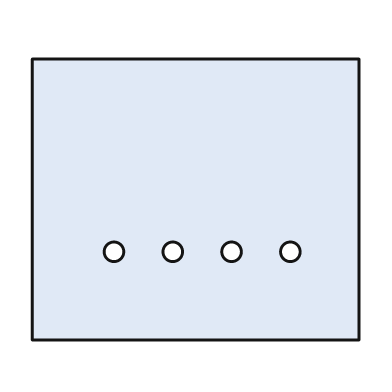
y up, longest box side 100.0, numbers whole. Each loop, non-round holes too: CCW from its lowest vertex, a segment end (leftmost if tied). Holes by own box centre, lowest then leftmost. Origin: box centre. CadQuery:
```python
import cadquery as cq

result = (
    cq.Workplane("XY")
    .moveTo(-50.0, -43.0)
    .lineTo(50.0, -43.0)
    .lineTo(50.0, 43.0)
    .lineTo(-50.0, 43.0)
    .close()
    .moveTo(-25.0, -16.0)
    .circle(3.0)
    .moveTo(-7.0, -16.0)
    .circle(3.0)
    .moveTo(11.0, -16.0)
    .circle(3.0)
    .moveTo(29.0, -16.0)
    .circle(3.0)
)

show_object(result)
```